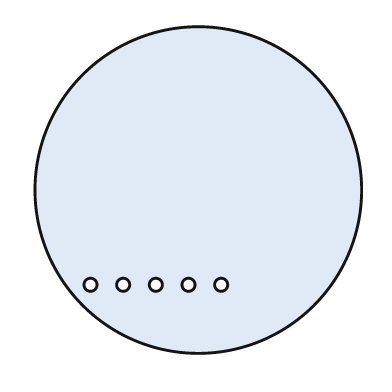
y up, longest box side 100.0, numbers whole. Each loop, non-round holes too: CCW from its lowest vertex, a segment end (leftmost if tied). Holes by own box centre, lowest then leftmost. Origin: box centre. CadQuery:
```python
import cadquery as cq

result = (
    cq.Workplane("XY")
    .moveTo(0.0, 0.0)
    .circle(50.0)
    .moveTo(-33.0, -29.0)
    .circle(2.0)
    .moveTo(-23.0, -29.0)
    .circle(2.0)
    .moveTo(-13.0, -29.0)
    .circle(2.0)
    .moveTo(-3.0, -29.0)
    .circle(2.0)
    .moveTo(7.0, -29.0)
    .circle(2.0)
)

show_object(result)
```